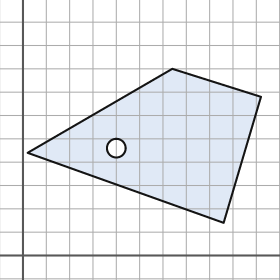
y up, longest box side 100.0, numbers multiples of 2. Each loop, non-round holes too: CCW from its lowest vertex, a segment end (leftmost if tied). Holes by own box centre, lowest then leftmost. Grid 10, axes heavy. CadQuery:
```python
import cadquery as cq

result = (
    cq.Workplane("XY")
    .moveTo(86.0, 14.0)
    .lineTo(102.0, 68.0)
    .lineTo(64.0, 80.0)
    .lineTo(2.0, 44.0)
    .close()
    .moveTo(40.0, 46.0)
    .circle(4.0)
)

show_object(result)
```